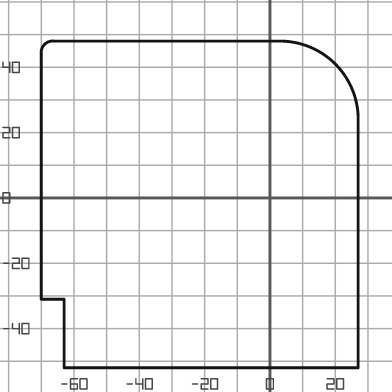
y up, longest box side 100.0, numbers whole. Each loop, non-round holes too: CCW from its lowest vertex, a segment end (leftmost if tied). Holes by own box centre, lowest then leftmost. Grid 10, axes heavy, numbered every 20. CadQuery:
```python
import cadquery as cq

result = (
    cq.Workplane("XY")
    .moveTo(-63.0, -52.0)
    .lineTo(27.0, -52.0)
    .lineTo(27.0, 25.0)
    .threePointArc((20.0, 41.0), (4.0, 48.0))
    .lineTo(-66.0, 48.0)
    .threePointArc((-69.0, 47.0), (-70.0, 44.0))
    .lineTo(-70.0, -31.0)
    .lineTo(-63.0, -31.0)
    .close()
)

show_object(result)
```